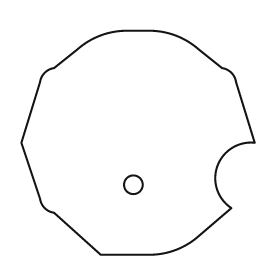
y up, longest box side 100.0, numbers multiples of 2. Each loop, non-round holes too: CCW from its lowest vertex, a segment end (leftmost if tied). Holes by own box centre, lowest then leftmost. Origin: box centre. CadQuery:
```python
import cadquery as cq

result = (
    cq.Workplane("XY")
    .moveTo(-16.0, -48.0)
    .lineTo(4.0, -48.0)
    .threePointArc((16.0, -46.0), (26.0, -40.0))
    .lineTo(40.0, -28.0)
    .threePointArc((34.0, -10.0), (50.0, 0.0))
    .lineTo(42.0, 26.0)
    .threePointArc((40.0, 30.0), (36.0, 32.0))
    .lineTo(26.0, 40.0)
    .threePointArc((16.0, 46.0), (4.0, 48.0))
    .lineTo(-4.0, 48.0)
    .threePointArc((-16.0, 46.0), (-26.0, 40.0))
    .lineTo(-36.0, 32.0)
    .threePointArc((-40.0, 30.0), (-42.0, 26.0))
    .lineTo(-50.0, 0.0)
    .lineTo(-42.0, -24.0)
    .threePointArc((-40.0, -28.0), (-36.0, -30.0))
    .close()
    .moveTo(-2.0, -18.0)
    .circle(4.0)
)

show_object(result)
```